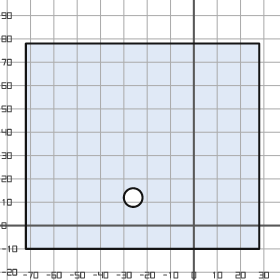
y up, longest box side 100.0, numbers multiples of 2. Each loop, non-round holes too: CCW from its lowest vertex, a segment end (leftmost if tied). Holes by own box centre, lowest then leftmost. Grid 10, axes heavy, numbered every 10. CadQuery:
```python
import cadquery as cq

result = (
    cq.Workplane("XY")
    .moveTo(-72.0, -10.0)
    .lineTo(28.0, -10.0)
    .lineTo(28.0, 78.0)
    .lineTo(-72.0, 78.0)
    .close()
    .moveTo(-26.0, 12.0)
    .circle(4.0)
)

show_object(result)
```